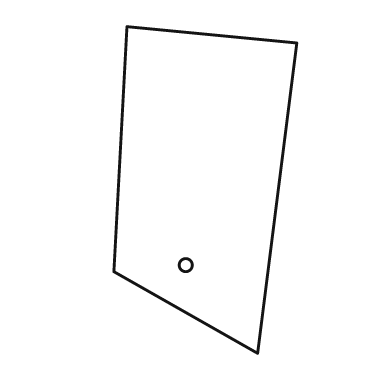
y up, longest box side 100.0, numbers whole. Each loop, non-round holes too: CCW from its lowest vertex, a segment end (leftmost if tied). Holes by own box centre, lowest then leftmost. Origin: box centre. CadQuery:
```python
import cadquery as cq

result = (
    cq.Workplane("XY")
    .moveTo(16.0, -50.0)
    .lineTo(28.0, 45.0)
    .lineTo(-24.0, 50.0)
    .lineTo(-28.0, -25.0)
    .close()
    .moveTo(-6.0, -23.0)
    .circle(2.0)
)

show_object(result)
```